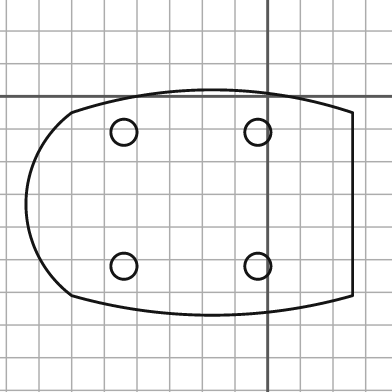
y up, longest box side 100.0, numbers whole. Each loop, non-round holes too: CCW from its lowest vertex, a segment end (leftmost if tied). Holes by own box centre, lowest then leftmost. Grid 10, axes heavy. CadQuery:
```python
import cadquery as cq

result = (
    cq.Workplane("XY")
    .moveTo(-60.0, -61.0)
    .threePointArc((-17.0, -67.0), (26.0, -61.0))
    .lineTo(26.0, -5.0)
    .threePointArc((-17.0, 2.0), (-60.0, -5.0))
    .threePointArc((-74.0, -33.0), (-60.0, -61.0))
    .close()
    .moveTo(-44.0, -52.0)
    .circle(4.0)
    .moveTo(-3.0, -52.0)
    .circle(4.0)
    .moveTo(-44.0, -11.0)
    .circle(4.0)
    .moveTo(-3.0, -11.0)
    .circle(4.0)
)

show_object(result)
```